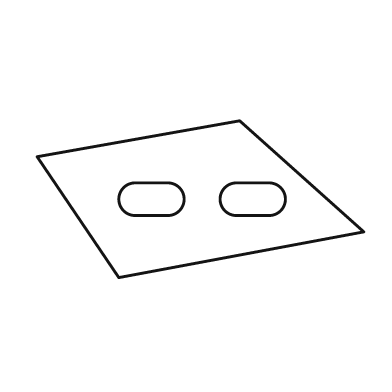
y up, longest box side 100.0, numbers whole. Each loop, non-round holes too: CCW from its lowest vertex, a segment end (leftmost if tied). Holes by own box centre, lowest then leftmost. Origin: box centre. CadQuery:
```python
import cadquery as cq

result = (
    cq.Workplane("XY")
    .moveTo(-25.0, -24.0)
    .lineTo(50.0, -10.0)
    .lineTo(12.0, 24.0)
    .lineTo(-50.0, 13.0)
    .close()
    .moveTo(-20.0, -5.0)
    .lineTo(-10.0, -5.0)
    .threePointArc((-5.0, 0.0), (-10.0, 5.0))
    .lineTo(-20.0, 5.0)
    .threePointArc((-25.0, 0.0), (-20.0, -5.0))
    .close()
    .moveTo(11.0, -5.0)
    .lineTo(21.0, -5.0)
    .threePointArc((26.0, 0.0), (21.0, 5.0))
    .lineTo(11.0, 5.0)
    .threePointArc((6.0, 0.0), (11.0, -5.0))
    .close()
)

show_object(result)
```